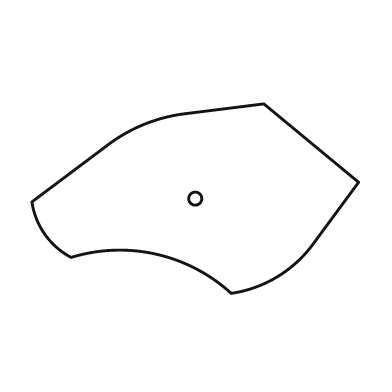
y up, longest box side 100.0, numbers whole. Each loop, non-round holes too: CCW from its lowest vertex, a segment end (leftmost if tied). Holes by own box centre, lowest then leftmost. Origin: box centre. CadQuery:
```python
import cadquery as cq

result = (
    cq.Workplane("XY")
    .moveTo(11.0, -29.0)
    .threePointArc((25.0, -24.0), (36.0, -14.0))
    .lineTo(50.0, 5.0)
    .lineTo(21.0, 29.0)
    .lineTo(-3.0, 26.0)
    .threePointArc((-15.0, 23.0), (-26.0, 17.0))
    .lineTo(-50.0, -1.0)
    .threePointArc((-46.0, -11.0), (-38.0, -18.0))
    .threePointArc((-12.0, -17.0), (11.0, -29.0))
    .close()
    .moveTo(0.0, 0.0)
    .circle(2.0)
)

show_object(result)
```